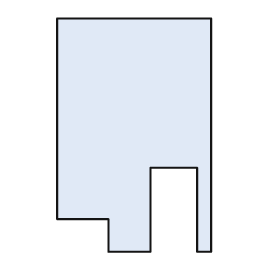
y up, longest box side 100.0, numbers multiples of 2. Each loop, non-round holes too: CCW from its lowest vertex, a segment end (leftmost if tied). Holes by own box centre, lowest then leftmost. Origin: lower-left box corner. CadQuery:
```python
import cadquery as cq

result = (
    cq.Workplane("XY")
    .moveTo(22.0, 0.0)
    .lineTo(40.0, 0.0)
    .lineTo(40.0, 36.0)
    .lineTo(60.0, 36.0)
    .lineTo(60.0, 0.0)
    .lineTo(66.0, 0.0)
    .lineTo(66.0, 100.0)
    .lineTo(0.0, 100.0)
    .lineTo(0.0, 14.0)
    .lineTo(22.0, 14.0)
    .close()
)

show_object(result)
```